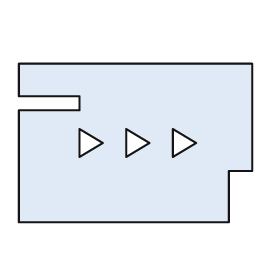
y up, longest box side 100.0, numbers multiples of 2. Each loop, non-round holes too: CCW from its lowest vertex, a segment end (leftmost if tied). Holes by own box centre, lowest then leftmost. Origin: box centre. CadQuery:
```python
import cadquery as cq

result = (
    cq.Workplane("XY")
    .moveTo(-50.0, -34.0)
    .lineTo(40.0, -34.0)
    .lineTo(40.0, -12.0)
    .lineTo(50.0, -12.0)
    .lineTo(50.0, 34.0)
    .lineTo(-50.0, 34.0)
    .lineTo(-50.0, 20.0)
    .lineTo(-24.0, 20.0)
    .lineTo(-24.0, 14.0)
    .lineTo(-50.0, 14.0)
    .close()
    .moveTo(-24.0, -6.0)
    .lineTo(-14.0, 0.0)
    .lineTo(-24.0, 6.0)
    .close()
    .moveTo(-4.0, -6.0)
    .lineTo(6.0, 0.0)
    .lineTo(-4.0, 6.0)
    .close()
    .moveTo(16.0, -6.0)
    .lineTo(26.0, 0.0)
    .lineTo(16.0, 6.0)
    .close()
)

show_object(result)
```